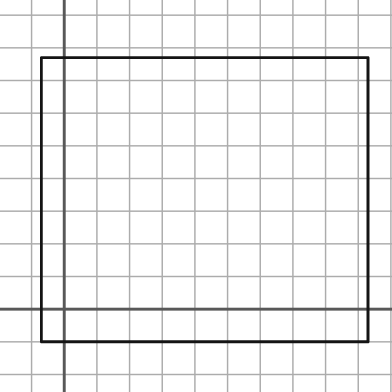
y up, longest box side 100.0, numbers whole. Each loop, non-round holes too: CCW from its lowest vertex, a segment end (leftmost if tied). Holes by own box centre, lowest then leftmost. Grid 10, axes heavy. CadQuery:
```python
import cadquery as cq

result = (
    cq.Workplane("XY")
    .moveTo(-7.0, -10.0)
    .lineTo(93.0, -10.0)
    .lineTo(93.0, 77.0)
    .lineTo(-7.0, 77.0)
    .close()
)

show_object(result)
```